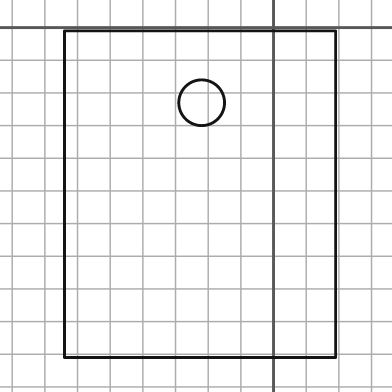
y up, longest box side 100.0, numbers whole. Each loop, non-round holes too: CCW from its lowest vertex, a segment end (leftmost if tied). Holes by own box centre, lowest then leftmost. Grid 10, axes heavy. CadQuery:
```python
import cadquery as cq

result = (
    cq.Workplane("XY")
    .moveTo(-64.0, -101.0)
    .lineTo(19.0, -101.0)
    .lineTo(19.0, -1.0)
    .lineTo(-64.0, -1.0)
    .close()
    .moveTo(-22.0, -23.0)
    .circle(7.0)
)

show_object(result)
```